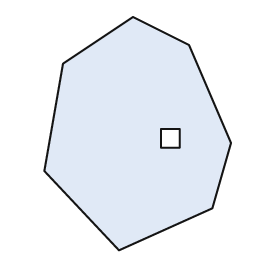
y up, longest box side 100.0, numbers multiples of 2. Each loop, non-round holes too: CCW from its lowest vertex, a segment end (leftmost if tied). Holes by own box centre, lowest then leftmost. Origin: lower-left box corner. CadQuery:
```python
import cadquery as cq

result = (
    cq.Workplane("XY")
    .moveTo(32.0, 0.0)
    .lineTo(72.0, 18.0)
    .lineTo(80.0, 46.0)
    .lineTo(62.0, 88.0)
    .lineTo(38.0, 100.0)
    .lineTo(8.0, 80.0)
    .lineTo(0.0, 34.0)
    .close()
    .moveTo(50.0, 44.0)
    .lineTo(58.0, 44.0)
    .lineTo(58.0, 52.0)
    .lineTo(50.0, 52.0)
    .close()
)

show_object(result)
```